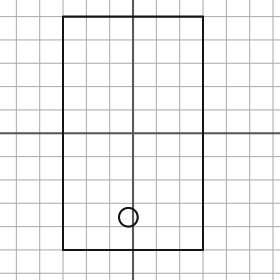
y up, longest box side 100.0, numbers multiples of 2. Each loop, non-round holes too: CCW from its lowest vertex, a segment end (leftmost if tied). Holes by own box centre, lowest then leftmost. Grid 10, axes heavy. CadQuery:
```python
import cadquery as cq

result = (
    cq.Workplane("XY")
    .moveTo(-30.0, -50.0)
    .lineTo(30.0, -50.0)
    .lineTo(30.0, 50.0)
    .lineTo(-30.0, 50.0)
    .close()
    .moveTo(-2.0, -36.0)
    .circle(4.0)
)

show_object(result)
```